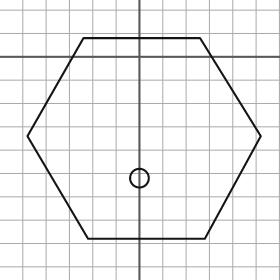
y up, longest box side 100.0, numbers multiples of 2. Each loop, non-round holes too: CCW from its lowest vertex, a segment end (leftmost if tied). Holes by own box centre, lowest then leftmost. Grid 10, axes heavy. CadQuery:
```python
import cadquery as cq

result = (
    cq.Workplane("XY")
    .moveTo(-22.0, -78.0)
    .lineTo(28.0, -78.0)
    .lineTo(52.0, -34.0)
    .lineTo(26.0, 8.0)
    .lineTo(-24.0, 8.0)
    .lineTo(-48.0, -34.0)
    .close()
    .moveTo(0.0, -52.0)
    .circle(4.0)
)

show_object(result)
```